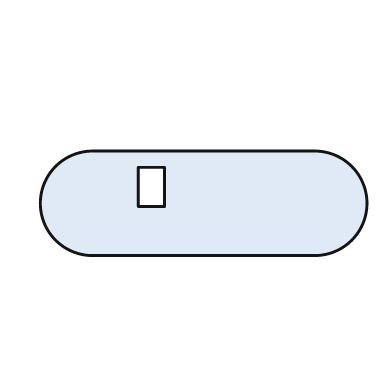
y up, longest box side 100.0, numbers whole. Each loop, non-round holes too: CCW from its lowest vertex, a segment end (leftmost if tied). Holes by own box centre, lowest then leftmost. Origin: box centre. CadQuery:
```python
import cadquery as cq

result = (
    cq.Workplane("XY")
    .moveTo(-34.0, -16.0)
    .lineTo(34.0, -16.0)
    .threePointArc((50.0, 0.0), (34.0, 16.0))
    .lineTo(-34.0, 16.0)
    .threePointArc((-50.0, 0.0), (-34.0, -16.0))
    .close()
    .moveTo(-20.0, -1.0)
    .lineTo(-12.0, -1.0)
    .lineTo(-12.0, 11.0)
    .lineTo(-20.0, 11.0)
    .close()
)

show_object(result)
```